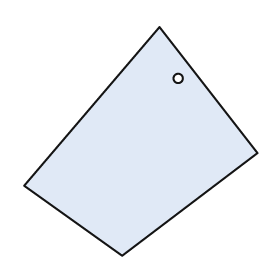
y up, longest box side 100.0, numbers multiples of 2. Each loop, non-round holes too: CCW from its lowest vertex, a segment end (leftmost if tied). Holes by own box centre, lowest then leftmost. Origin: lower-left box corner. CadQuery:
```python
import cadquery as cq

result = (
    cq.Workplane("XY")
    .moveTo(42.0, 0.0)
    .lineTo(100.0, 44.0)
    .lineTo(58.0, 98.0)
    .lineTo(0.0, 30.0)
    .close()
    .moveTo(66.0, 76.0)
    .circle(2.0)
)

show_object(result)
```